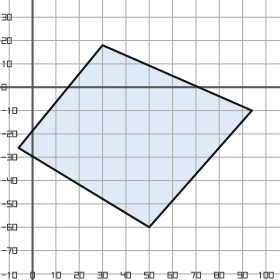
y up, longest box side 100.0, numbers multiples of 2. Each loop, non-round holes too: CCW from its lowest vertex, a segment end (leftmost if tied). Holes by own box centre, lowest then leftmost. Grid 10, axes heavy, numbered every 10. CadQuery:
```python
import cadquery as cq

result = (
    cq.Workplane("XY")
    .moveTo(50.0, -60.0)
    .lineTo(94.0, -10.0)
    .lineTo(30.0, 18.0)
    .lineTo(-6.0, -26.0)
    .close()
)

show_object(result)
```